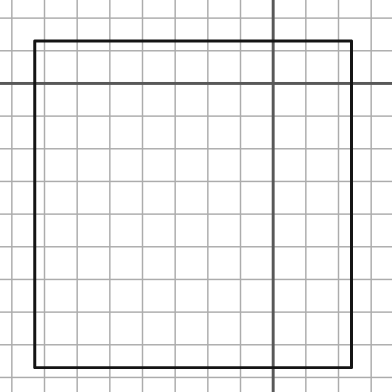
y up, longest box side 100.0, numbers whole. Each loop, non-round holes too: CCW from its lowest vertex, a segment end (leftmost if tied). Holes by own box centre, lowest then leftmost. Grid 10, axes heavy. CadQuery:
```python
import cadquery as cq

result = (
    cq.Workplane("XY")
    .moveTo(-73.0, -87.0)
    .lineTo(24.0, -87.0)
    .lineTo(24.0, 13.0)
    .lineTo(-73.0, 13.0)
    .close()
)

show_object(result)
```